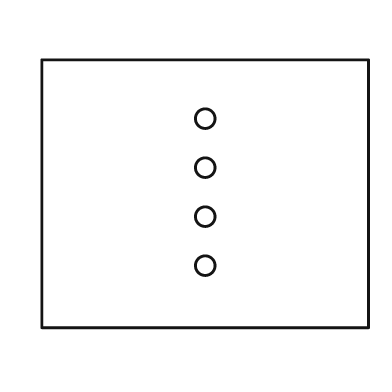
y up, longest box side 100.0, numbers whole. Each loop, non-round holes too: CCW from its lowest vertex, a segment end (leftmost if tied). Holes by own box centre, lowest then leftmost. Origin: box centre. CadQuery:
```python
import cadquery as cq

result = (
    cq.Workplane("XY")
    .moveTo(-50.0, -41.0)
    .lineTo(50.0, -41.0)
    .lineTo(50.0, 41.0)
    .lineTo(-50.0, 41.0)
    .close()
    .moveTo(0.0, -22.0)
    .circle(3.0)
    .moveTo(0.0, -7.0)
    .circle(3.0)
    .moveTo(0.0, 8.0)
    .circle(3.0)
    .moveTo(0.0, 23.0)
    .circle(3.0)
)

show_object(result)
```